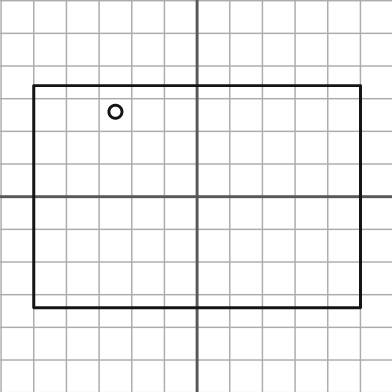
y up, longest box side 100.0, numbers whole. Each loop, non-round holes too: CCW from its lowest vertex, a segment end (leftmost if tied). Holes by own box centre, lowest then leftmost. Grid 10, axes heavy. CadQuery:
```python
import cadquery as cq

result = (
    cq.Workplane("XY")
    .moveTo(-50.0, -34.0)
    .lineTo(50.0, -34.0)
    .lineTo(50.0, 34.0)
    .lineTo(-50.0, 34.0)
    .close()
    .moveTo(-25.0, 26.0)
    .circle(2.0)
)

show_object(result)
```